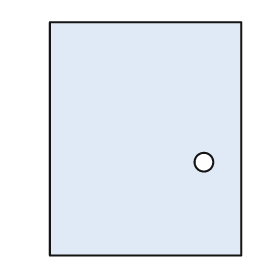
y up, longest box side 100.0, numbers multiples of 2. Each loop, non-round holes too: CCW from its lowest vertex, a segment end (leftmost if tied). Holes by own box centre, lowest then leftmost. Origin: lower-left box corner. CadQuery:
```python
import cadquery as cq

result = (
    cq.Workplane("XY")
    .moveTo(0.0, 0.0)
    .lineTo(82.0, 0.0)
    .lineTo(82.0, 100.0)
    .lineTo(0.0, 100.0)
    .close()
    .moveTo(66.0, 40.0)
    .circle(4.0)
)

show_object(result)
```